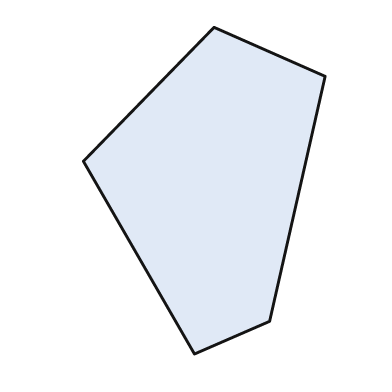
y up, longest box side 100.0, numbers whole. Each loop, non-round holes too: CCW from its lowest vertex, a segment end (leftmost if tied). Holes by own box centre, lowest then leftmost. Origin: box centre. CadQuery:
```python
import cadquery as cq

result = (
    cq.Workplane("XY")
    .moveTo(-3.0, -50.0)
    .lineTo(20.0, -40.0)
    .lineTo(37.0, 35.0)
    .lineTo(3.0, 50.0)
    .lineTo(-37.0, 9.0)
    .close()
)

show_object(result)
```